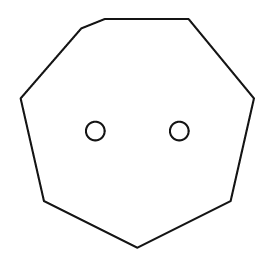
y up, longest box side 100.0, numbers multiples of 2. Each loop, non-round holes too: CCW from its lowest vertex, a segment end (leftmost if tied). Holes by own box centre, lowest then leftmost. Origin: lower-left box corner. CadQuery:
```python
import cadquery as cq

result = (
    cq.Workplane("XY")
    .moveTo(50.0, 0.0)
    .lineTo(90.0, 20.0)
    .lineTo(100.0, 64.0)
    .lineTo(72.0, 98.0)
    .lineTo(36.0, 98.0)
    .lineTo(26.0, 94.0)
    .lineTo(0.0, 64.0)
    .lineTo(10.0, 20.0)
    .close()
    .moveTo(32.0, 50.0)
    .circle(4.0)
    .moveTo(68.0, 50.0)
    .circle(4.0)
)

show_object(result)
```